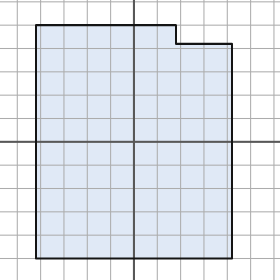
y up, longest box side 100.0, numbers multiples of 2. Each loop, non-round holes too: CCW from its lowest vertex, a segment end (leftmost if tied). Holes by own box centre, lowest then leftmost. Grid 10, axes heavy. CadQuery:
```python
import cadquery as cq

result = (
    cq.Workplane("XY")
    .moveTo(-42.0, -50.0)
    .lineTo(42.0, -50.0)
    .lineTo(42.0, 42.0)
    .lineTo(18.0, 42.0)
    .lineTo(18.0, 50.0)
    .lineTo(-42.0, 50.0)
    .close()
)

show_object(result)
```